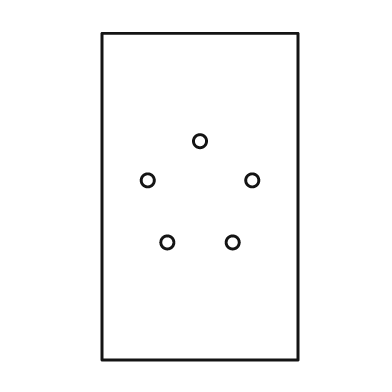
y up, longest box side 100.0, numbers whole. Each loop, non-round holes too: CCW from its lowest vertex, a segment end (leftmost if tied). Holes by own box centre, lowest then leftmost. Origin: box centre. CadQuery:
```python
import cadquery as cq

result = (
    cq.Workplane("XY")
    .moveTo(-30.0, -50.0)
    .lineTo(30.0, -50.0)
    .lineTo(30.0, 50.0)
    .lineTo(-30.0, 50.0)
    .close()
    .moveTo(-10.0, -14.0)
    .circle(2.0)
    .moveTo(10.0, -14.0)
    .circle(2.0)
    .moveTo(-16.0, 5.0)
    .circle(2.0)
    .moveTo(16.0, 5.0)
    .circle(2.0)
    .moveTo(0.0, 17.0)
    .circle(2.0)
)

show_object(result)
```